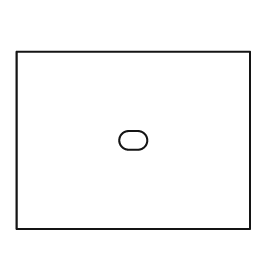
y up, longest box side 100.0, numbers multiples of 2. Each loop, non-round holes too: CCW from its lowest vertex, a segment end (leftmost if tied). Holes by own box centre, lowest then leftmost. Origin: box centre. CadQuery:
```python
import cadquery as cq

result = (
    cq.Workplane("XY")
    .moveTo(-50.0, -38.0)
    .lineTo(50.0, -38.0)
    .lineTo(50.0, 38.0)
    .lineTo(-50.0, 38.0)
    .close()
    .moveTo(-2.0, -4.0)
    .lineTo(2.0, -4.0)
    .threePointArc((6.0, 0.0), (2.0, 4.0))
    .lineTo(-2.0, 4.0)
    .threePointArc((-6.0, 0.0), (-2.0, -4.0))
    .close()
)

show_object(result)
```